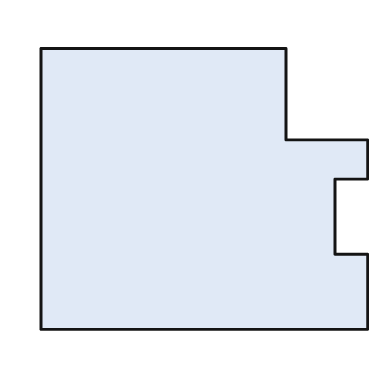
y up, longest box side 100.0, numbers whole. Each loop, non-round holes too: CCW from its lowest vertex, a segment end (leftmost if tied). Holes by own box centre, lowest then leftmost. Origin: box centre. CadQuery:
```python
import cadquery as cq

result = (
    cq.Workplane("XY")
    .moveTo(-50.0, -43.0)
    .lineTo(50.0, -43.0)
    .lineTo(50.0, -20.0)
    .lineTo(40.0, -20.0)
    .lineTo(40.0, 3.0)
    .lineTo(50.0, 3.0)
    .lineTo(50.0, 15.0)
    .lineTo(25.0, 15.0)
    .lineTo(25.0, 43.0)
    .lineTo(-50.0, 43.0)
    .close()
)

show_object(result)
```